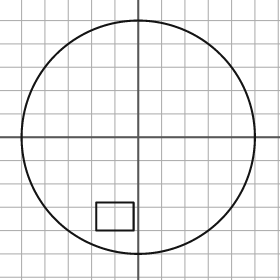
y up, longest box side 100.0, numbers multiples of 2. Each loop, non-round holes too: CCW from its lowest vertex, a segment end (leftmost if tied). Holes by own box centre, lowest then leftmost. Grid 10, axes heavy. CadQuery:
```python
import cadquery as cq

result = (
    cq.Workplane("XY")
    .moveTo(0.0, 0.0)
    .circle(50.0)
    .moveTo(-18.0, -40.0)
    .lineTo(-2.0, -40.0)
    .lineTo(-2.0, -28.0)
    .lineTo(-18.0, -28.0)
    .close()
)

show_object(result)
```